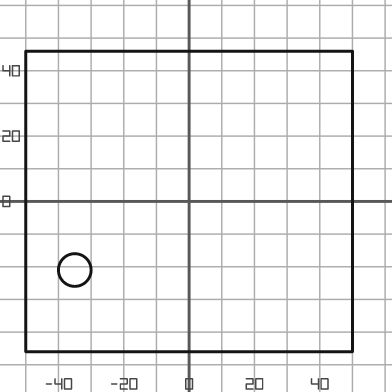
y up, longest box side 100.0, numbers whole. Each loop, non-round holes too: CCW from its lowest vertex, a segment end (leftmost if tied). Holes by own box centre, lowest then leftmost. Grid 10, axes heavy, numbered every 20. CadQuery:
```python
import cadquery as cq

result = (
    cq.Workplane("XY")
    .moveTo(-50.0, -46.0)
    .lineTo(50.0, -46.0)
    .lineTo(50.0, 46.0)
    .lineTo(-50.0, 46.0)
    .close()
    .moveTo(-35.0, -21.0)
    .circle(5.0)
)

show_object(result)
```